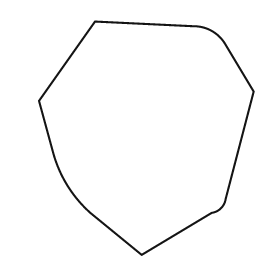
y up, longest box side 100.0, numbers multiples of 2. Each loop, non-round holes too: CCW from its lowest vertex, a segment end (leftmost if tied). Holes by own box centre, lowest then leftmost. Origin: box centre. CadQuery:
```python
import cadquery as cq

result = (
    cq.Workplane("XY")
    .moveTo(-2.0, -50.0)
    .lineTo(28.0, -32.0)
    .threePointArc((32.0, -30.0), (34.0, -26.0))
    .lineTo(46.0, 20.0)
    .lineTo(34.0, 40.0)
    .threePointArc((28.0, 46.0), (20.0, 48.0))
    .lineTo(-22.0, 50.0)
    .lineTo(-46.0, 16.0)
    .lineTo(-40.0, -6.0)
    .threePointArc((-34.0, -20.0), (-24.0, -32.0))
    .close()
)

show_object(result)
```